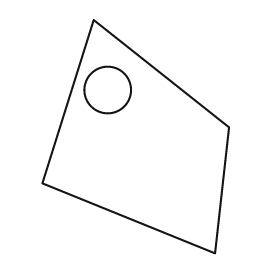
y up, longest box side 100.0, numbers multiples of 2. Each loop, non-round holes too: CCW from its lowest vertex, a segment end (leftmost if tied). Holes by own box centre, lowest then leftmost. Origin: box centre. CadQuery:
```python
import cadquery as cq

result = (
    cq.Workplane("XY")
    .moveTo(34.0, -50.0)
    .lineTo(40.0, 4.0)
    .lineTo(-18.0, 50.0)
    .lineTo(-40.0, -20.0)
    .close()
    .moveTo(-12.0, 20.0)
    .circle(10.0)
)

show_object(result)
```